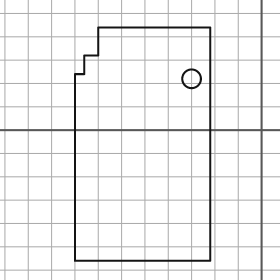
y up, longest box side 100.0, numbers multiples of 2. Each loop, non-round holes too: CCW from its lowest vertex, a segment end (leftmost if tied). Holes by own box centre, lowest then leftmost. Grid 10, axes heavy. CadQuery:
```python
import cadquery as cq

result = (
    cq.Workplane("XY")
    .moveTo(-80.0, -56.0)
    .lineTo(-22.0, -56.0)
    .lineTo(-22.0, 44.0)
    .lineTo(-70.0, 44.0)
    .lineTo(-70.0, 32.0)
    .lineTo(-76.0, 32.0)
    .lineTo(-76.0, 24.0)
    .lineTo(-80.0, 24.0)
    .close()
    .moveTo(-30.0, 22.0)
    .circle(4.0)
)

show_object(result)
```